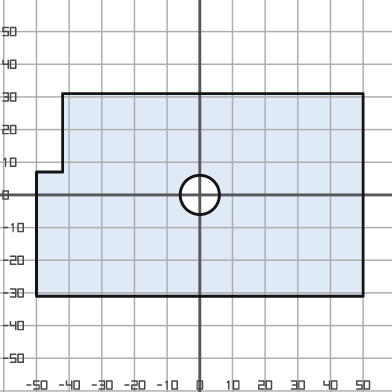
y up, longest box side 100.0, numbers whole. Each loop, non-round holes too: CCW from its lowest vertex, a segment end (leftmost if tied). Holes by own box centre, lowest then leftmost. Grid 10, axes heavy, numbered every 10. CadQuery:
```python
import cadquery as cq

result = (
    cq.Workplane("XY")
    .moveTo(-50.0, -31.0)
    .lineTo(50.0, -31.0)
    .lineTo(50.0, 31.0)
    .lineTo(-42.0, 31.0)
    .lineTo(-42.0, 7.0)
    .lineTo(-50.0, 7.0)
    .close()
    .moveTo(0.0, 0.0)
    .circle(6.0)
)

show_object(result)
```